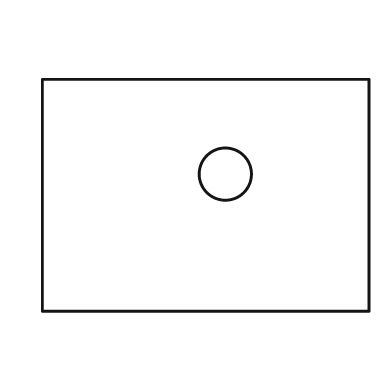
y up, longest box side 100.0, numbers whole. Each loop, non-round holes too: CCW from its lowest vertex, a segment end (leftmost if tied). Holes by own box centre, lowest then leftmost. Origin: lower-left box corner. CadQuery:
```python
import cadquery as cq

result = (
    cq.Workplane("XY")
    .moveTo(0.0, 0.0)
    .lineTo(100.0, 0.0)
    .lineTo(100.0, 71.0)
    .lineTo(0.0, 71.0)
    .close()
    .moveTo(56.0, 42.0)
    .circle(8.0)
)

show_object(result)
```